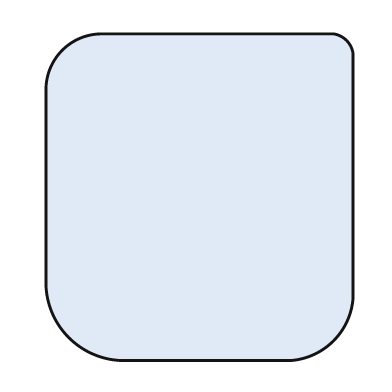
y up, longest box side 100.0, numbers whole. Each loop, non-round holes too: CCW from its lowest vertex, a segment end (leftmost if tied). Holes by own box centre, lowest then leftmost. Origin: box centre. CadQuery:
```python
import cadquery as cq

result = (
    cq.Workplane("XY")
    .moveTo(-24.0, -50.0)
    .lineTo(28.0, -50.0)
    .threePointArc((41.0, -44.0), (47.0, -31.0))
    .lineTo(47.0, 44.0)
    .threePointArc((45.0, 48.0), (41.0, 50.0))
    .lineTo(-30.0, 50.0)
    .threePointArc((-42.0, 45.0), (-47.0, 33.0))
    .lineTo(-47.0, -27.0)
    .threePointArc((-40.0, -43.0), (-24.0, -50.0))
    .close()
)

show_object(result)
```